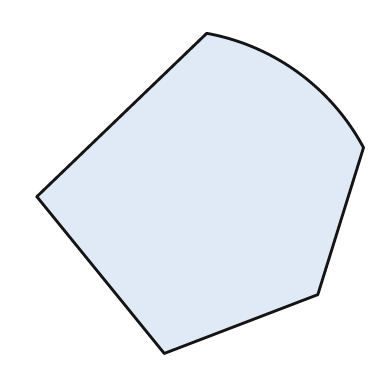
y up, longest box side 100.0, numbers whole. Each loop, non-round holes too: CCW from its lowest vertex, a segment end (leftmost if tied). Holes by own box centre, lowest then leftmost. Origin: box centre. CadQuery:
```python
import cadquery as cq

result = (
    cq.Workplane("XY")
    .moveTo(-11.0, -49.0)
    .lineTo(36.0, -31.0)
    .lineTo(50.0, 14.0)
    .threePointArc((30.0, 37.0), (2.0, 49.0))
    .lineTo(-50.0, -1.0)
    .close()
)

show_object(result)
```